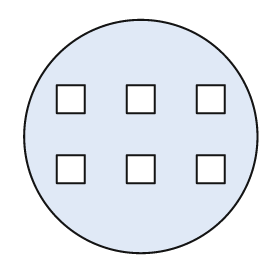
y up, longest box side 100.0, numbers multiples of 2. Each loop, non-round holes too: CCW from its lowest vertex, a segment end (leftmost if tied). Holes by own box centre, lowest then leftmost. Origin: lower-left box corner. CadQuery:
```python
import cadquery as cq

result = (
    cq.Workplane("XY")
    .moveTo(50.0, 50.0)
    .circle(50.0)
    .moveTo(14.0, 30.0)
    .lineTo(26.0, 30.0)
    .lineTo(26.0, 42.0)
    .lineTo(14.0, 42.0)
    .close()
    .moveTo(44.0, 30.0)
    .lineTo(56.0, 30.0)
    .lineTo(56.0, 42.0)
    .lineTo(44.0, 42.0)
    .close()
    .moveTo(74.0, 30.0)
    .lineTo(86.0, 30.0)
    .lineTo(86.0, 42.0)
    .lineTo(74.0, 42.0)
    .close()
    .moveTo(14.0, 60.0)
    .lineTo(26.0, 60.0)
    .lineTo(26.0, 72.0)
    .lineTo(14.0, 72.0)
    .close()
    .moveTo(44.0, 60.0)
    .lineTo(56.0, 60.0)
    .lineTo(56.0, 72.0)
    .lineTo(44.0, 72.0)
    .close()
    .moveTo(74.0, 60.0)
    .lineTo(86.0, 60.0)
    .lineTo(86.0, 72.0)
    .lineTo(74.0, 72.0)
    .close()
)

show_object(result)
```